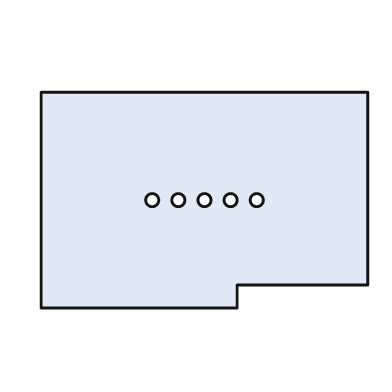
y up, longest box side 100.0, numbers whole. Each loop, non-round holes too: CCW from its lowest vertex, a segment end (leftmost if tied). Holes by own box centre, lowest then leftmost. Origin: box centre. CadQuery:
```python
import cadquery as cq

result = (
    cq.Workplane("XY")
    .moveTo(-50.0, -33.0)
    .lineTo(10.0, -33.0)
    .lineTo(10.0, -26.0)
    .lineTo(50.0, -26.0)
    .lineTo(50.0, 33.0)
    .lineTo(-50.0, 33.0)
    .close()
    .moveTo(-16.0, 0.0)
    .circle(2.0)
    .moveTo(-8.0, 0.0)
    .circle(2.0)
    .moveTo(0.0, 0.0)
    .circle(2.0)
    .moveTo(8.0, 0.0)
    .circle(2.0)
    .moveTo(16.0, 0.0)
    .circle(2.0)
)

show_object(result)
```